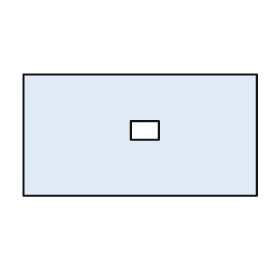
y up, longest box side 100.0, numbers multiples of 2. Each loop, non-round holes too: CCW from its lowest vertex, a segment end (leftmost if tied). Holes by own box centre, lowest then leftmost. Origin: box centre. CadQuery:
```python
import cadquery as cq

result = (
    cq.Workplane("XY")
    .moveTo(-50.0, -26.0)
    .lineTo(50.0, -26.0)
    .lineTo(50.0, 26.0)
    .lineTo(-50.0, 26.0)
    .close()
    .moveTo(-4.0, -2.0)
    .lineTo(8.0, -2.0)
    .lineTo(8.0, 6.0)
    .lineTo(-4.0, 6.0)
    .close()
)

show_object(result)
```